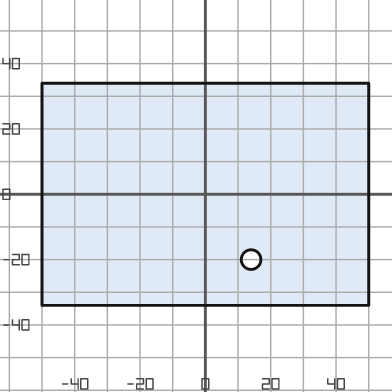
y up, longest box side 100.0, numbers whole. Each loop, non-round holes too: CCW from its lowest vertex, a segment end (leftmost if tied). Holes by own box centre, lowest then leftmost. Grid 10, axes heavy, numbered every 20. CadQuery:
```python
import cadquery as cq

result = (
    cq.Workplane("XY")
    .moveTo(-50.0, -34.0)
    .lineTo(50.0, -34.0)
    .lineTo(50.0, 34.0)
    .lineTo(-50.0, 34.0)
    .close()
    .moveTo(14.0, -20.0)
    .circle(3.0)
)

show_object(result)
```